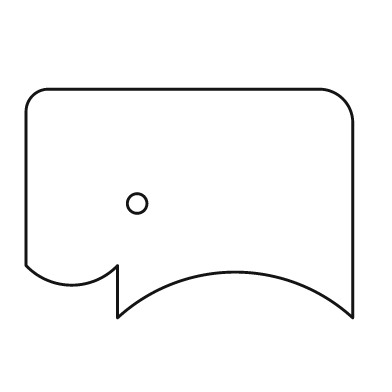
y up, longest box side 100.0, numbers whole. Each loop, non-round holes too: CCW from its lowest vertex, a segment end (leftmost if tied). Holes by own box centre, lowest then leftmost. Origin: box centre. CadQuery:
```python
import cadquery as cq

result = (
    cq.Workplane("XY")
    .moveTo(-22.0, -35.0)
    .threePointArc((14.0, -21.0), (50.0, -35.0))
    .lineTo(50.0, 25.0)
    .threePointArc((47.0, 32.0), (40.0, 35.0))
    .lineTo(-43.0, 35.0)
    .threePointArc((-48.0, 33.0), (-50.0, 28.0))
    .lineTo(-50.0, -19.0)
    .threePointArc((-36.0, -25.0), (-22.0, -19.0))
    .close()
    .moveTo(-16.0, 0.0)
    .circle(3.0)
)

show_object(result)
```